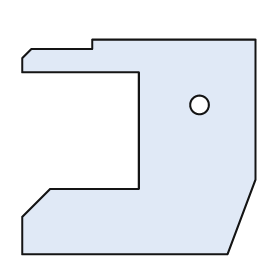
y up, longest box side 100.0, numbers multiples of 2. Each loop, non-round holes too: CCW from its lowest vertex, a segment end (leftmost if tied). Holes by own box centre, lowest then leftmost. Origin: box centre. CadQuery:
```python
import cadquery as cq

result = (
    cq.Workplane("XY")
    .moveTo(-50.0, -46.0)
    .lineTo(38.0, -46.0)
    .lineTo(50.0, -14.0)
    .lineTo(50.0, 46.0)
    .lineTo(-20.0, 46.0)
    .lineTo(-20.0, 42.0)
    .lineTo(-46.0, 42.0)
    .lineTo(-50.0, 38.0)
    .lineTo(-50.0, 32.0)
    .lineTo(0.0, 32.0)
    .lineTo(0.0, -18.0)
    .lineTo(-38.0, -18.0)
    .lineTo(-50.0, -30.0)
    .close()
    .moveTo(26.0, 18.0)
    .circle(4.0)
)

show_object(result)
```